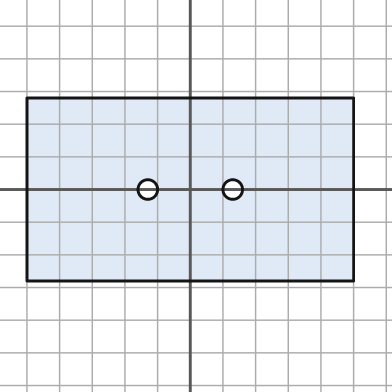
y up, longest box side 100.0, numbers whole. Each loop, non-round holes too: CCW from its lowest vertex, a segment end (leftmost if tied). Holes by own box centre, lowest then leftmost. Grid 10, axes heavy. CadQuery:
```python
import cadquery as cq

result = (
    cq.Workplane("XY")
    .moveTo(-50.0, -28.0)
    .lineTo(50.0, -28.0)
    .lineTo(50.0, 28.0)
    .lineTo(-50.0, 28.0)
    .close()
    .moveTo(-13.0, 0.0)
    .circle(3.0)
    .moveTo(13.0, 0.0)
    .circle(3.0)
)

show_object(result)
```